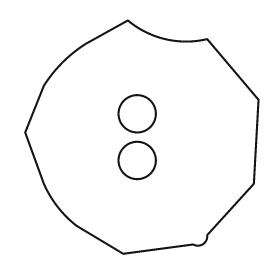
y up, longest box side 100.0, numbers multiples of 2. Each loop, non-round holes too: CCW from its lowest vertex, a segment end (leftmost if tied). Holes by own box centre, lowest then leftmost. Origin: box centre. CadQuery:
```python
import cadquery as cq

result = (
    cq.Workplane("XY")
    .moveTo(-8.0, -50.0)
    .lineTo(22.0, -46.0)
    .threePointArc((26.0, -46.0), (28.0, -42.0))
    .lineTo(48.0, -20.0)
    .lineTo(50.0, 16.0)
    .lineTo(28.0, 42.0)
    .threePointArc((10.0, 42.0), (-6.0, 50.0))
    .lineTo(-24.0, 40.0)
    .threePointArc((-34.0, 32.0), (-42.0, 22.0))
    .lineTo(-50.0, 2.0)
    .lineTo(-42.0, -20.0)
    .threePointArc((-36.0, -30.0), (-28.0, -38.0))
    .close()
    .moveTo(-2.0, -10.0)
    .circle(8.0)
    .moveTo(-2.0, 10.0)
    .circle(8.0)
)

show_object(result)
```